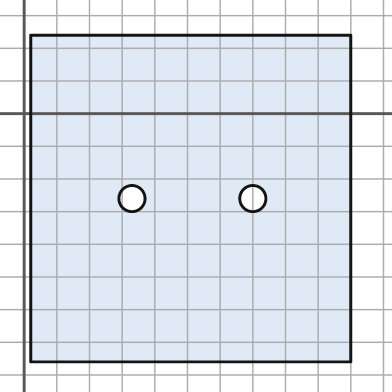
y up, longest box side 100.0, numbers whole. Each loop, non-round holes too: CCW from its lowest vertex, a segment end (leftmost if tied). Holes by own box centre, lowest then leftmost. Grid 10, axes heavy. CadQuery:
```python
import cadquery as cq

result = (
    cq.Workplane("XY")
    .moveTo(2.0, -76.0)
    .lineTo(100.0, -76.0)
    .lineTo(100.0, 24.0)
    .lineTo(2.0, 24.0)
    .close()
    .moveTo(33.0, -26.0)
    .circle(4.0)
    .moveTo(70.0, -26.0)
    .circle(4.0)
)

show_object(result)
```